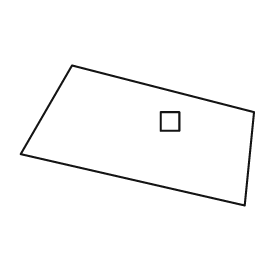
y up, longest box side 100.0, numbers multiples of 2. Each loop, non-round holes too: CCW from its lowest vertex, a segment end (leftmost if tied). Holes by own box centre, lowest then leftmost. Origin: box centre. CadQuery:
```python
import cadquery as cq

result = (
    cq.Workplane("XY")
    .moveTo(46.0, -30.0)
    .lineTo(50.0, 10.0)
    .lineTo(-28.0, 30.0)
    .lineTo(-50.0, -8.0)
    .close()
    .moveTo(10.0, 2.0)
    .lineTo(18.0, 2.0)
    .lineTo(18.0, 10.0)
    .lineTo(10.0, 10.0)
    .close()
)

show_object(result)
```